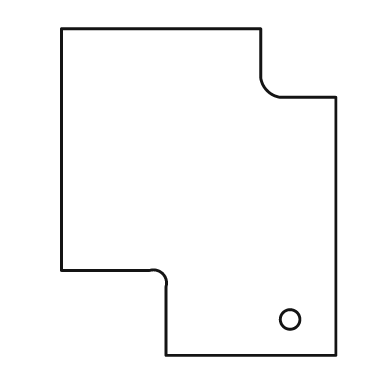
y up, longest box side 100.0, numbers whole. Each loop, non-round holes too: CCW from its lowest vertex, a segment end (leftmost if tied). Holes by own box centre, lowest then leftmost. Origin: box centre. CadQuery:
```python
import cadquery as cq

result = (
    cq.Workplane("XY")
    .moveTo(-10.0, -50.0)
    .lineTo(42.0, -50.0)
    .lineTo(42.0, 29.0)
    .lineTo(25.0, 29.0)
    .threePointArc((21.0, 31.0), (19.0, 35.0))
    .lineTo(19.0, 50.0)
    .lineTo(-42.0, 50.0)
    .lineTo(-42.0, -24.0)
    .lineTo(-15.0, -24.0)
    .threePointArc((-11.0, -25.0), (-10.0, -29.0))
    .close()
    .moveTo(28.0, -39.0)
    .circle(3.0)
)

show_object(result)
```